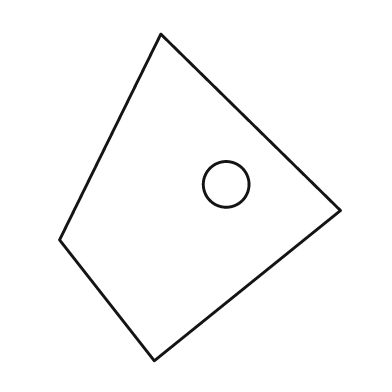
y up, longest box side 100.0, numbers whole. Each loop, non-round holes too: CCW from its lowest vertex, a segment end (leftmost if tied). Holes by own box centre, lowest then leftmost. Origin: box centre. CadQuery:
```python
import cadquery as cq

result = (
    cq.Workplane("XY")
    .moveTo(-14.0, -50.0)
    .lineTo(43.0, -4.0)
    .lineTo(-12.0, 50.0)
    .lineTo(-43.0, -13.0)
    .close()
    .moveTo(8.0, 4.0)
    .circle(7.0)
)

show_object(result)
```